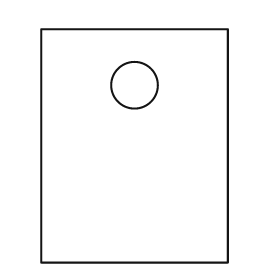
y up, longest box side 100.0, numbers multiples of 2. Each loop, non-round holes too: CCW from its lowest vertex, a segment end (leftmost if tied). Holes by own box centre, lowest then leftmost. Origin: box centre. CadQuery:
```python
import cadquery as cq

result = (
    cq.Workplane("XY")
    .moveTo(-40.0, -50.0)
    .lineTo(40.0, -50.0)
    .lineTo(40.0, 50.0)
    .lineTo(-40.0, 50.0)
    .close()
    .moveTo(0.0, 26.0)
    .circle(10.0)
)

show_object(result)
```